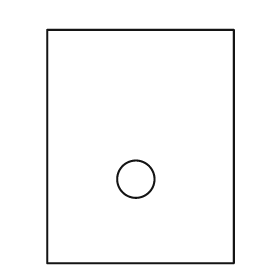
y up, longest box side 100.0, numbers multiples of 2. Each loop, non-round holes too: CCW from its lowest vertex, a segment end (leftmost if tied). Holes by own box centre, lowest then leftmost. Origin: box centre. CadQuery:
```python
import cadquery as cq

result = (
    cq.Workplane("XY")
    .moveTo(-40.0, -50.0)
    .lineTo(40.0, -50.0)
    .lineTo(40.0, 50.0)
    .lineTo(-40.0, 50.0)
    .close()
    .moveTo(-2.0, -14.0)
    .circle(8.0)
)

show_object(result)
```